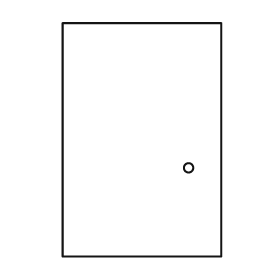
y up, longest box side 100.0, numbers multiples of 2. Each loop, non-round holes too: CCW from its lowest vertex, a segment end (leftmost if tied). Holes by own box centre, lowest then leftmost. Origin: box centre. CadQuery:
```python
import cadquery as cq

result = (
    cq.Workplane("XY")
    .moveTo(-34.0, -50.0)
    .lineTo(34.0, -50.0)
    .lineTo(34.0, 50.0)
    .lineTo(-34.0, 50.0)
    .close()
    .moveTo(20.0, -12.0)
    .circle(2.0)
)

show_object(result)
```